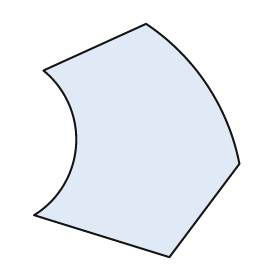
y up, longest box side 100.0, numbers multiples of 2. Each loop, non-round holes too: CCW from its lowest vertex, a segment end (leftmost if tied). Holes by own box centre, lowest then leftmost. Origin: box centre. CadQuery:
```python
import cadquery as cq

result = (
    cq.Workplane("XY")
    .moveTo(14.0, -50.0)
    .lineTo(44.0, -10.0)
    .threePointArc((30.0, 24.0), (4.0, 50.0))
    .lineTo(-40.0, 30.0)
    .threePointArc((-26.0, -2.0), (-44.0, -32.0))
    .close()
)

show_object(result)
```